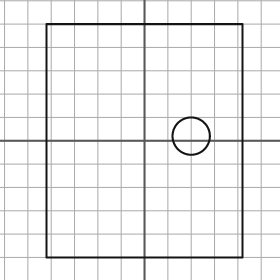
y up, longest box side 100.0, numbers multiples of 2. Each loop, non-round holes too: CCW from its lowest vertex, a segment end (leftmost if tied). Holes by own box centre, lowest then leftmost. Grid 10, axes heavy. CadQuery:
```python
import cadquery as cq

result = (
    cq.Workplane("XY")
    .moveTo(-42.0, -50.0)
    .lineTo(42.0, -50.0)
    .lineTo(42.0, 50.0)
    .lineTo(-42.0, 50.0)
    .close()
    .moveTo(20.0, 2.0)
    .circle(8.0)
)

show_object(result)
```